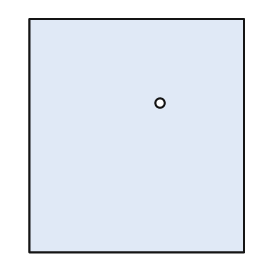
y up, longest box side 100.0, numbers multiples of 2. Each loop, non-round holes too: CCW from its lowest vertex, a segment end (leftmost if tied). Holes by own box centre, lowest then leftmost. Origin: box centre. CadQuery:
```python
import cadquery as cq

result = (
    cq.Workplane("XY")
    .moveTo(-46.0, -50.0)
    .lineTo(46.0, -50.0)
    .lineTo(46.0, 50.0)
    .lineTo(-46.0, 50.0)
    .close()
    .moveTo(10.0, 14.0)
    .circle(2.0)
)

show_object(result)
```